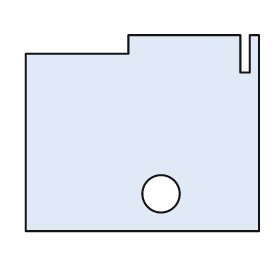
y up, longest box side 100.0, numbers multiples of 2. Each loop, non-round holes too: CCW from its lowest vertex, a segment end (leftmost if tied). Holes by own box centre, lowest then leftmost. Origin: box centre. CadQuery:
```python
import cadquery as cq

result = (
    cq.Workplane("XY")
    .moveTo(-50.0, -42.0)
    .lineTo(50.0, -42.0)
    .lineTo(50.0, 42.0)
    .lineTo(46.0, 42.0)
    .lineTo(46.0, 26.0)
    .lineTo(42.0, 26.0)
    .lineTo(42.0, 42.0)
    .lineTo(-6.0, 42.0)
    .lineTo(-6.0, 34.0)
    .lineTo(-50.0, 34.0)
    .close()
    .moveTo(8.0, -26.0)
    .circle(8.0)
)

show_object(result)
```